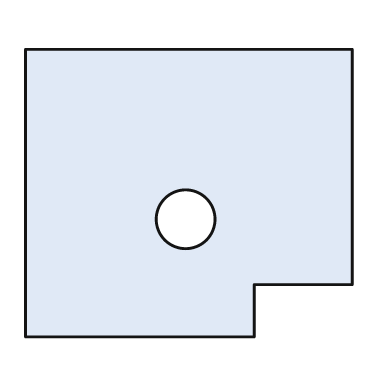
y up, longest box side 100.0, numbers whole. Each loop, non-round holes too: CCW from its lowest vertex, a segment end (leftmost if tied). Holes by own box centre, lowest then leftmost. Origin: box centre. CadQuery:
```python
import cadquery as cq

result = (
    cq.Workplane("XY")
    .moveTo(-50.0, -44.0)
    .lineTo(20.0, -44.0)
    .lineTo(20.0, -28.0)
    .lineTo(50.0, -28.0)
    .lineTo(50.0, 44.0)
    .lineTo(-50.0, 44.0)
    .close()
    .moveTo(-1.0, -8.0)
    .circle(9.0)
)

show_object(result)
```